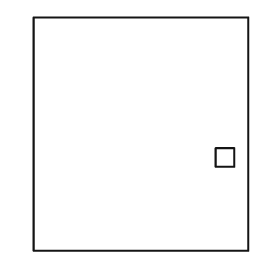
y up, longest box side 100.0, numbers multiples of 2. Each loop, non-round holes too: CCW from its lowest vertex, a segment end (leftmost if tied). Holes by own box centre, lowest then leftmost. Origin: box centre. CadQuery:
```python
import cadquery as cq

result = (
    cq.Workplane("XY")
    .moveTo(-46.0, -50.0)
    .lineTo(46.0, -50.0)
    .lineTo(46.0, 50.0)
    .lineTo(-46.0, 50.0)
    .close()
    .moveTo(32.0, -14.0)
    .lineTo(40.0, -14.0)
    .lineTo(40.0, -6.0)
    .lineTo(32.0, -6.0)
    .close()
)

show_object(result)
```